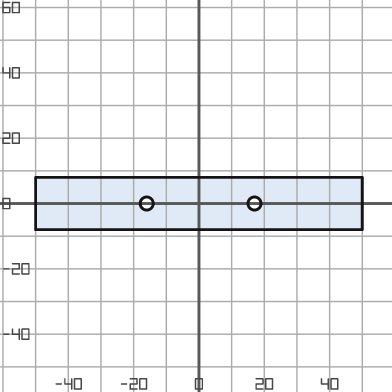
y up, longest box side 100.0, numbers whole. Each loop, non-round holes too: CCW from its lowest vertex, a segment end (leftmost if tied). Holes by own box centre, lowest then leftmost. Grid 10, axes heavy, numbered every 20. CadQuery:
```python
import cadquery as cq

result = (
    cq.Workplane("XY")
    .moveTo(-50.0, -8.0)
    .lineTo(50.0, -8.0)
    .lineTo(50.0, 8.0)
    .lineTo(-50.0, 8.0)
    .close()
    .moveTo(-16.0, 0.0)
    .circle(2.0)
    .moveTo(17.0, 0.0)
    .circle(2.0)
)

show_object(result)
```